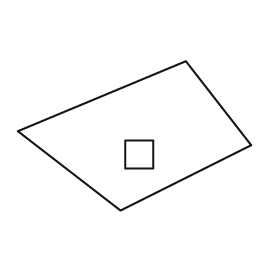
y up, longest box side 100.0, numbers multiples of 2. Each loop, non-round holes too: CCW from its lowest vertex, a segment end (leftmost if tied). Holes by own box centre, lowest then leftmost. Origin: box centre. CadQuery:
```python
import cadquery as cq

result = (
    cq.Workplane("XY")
    .moveTo(-6.0, -32.0)
    .lineTo(50.0, -4.0)
    .lineTo(22.0, 32.0)
    .lineTo(-50.0, 2.0)
    .close()
    .moveTo(-4.0, -14.0)
    .lineTo(8.0, -14.0)
    .lineTo(8.0, -2.0)
    .lineTo(-4.0, -2.0)
    .close()
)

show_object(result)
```